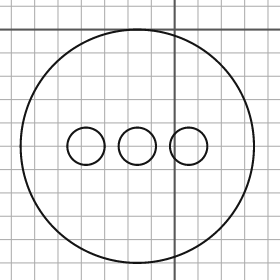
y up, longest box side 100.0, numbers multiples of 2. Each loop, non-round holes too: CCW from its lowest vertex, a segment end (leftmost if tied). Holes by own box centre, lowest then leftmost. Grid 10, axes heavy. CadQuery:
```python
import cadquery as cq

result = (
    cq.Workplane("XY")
    .moveTo(-16.0, -50.0)
    .circle(50.0)
    .moveTo(-38.0, -50.0)
    .circle(8.0)
    .moveTo(-16.0, -50.0)
    .circle(8.0)
    .moveTo(6.0, -50.0)
    .circle(8.0)
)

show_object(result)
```